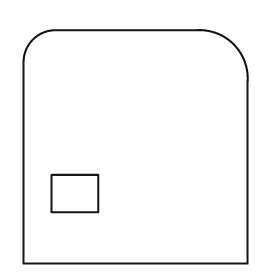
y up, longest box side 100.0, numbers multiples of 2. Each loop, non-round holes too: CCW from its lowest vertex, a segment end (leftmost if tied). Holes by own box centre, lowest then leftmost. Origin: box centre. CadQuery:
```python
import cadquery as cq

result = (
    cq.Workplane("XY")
    .moveTo(-48.0, -50.0)
    .lineTo(48.0, -50.0)
    .lineTo(48.0, 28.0)
    .threePointArc((42.0, 44.0), (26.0, 50.0))
    .lineTo(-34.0, 50.0)
    .threePointArc((-44.0, 46.0), (-48.0, 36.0))
    .close()
    .moveTo(-36.0, -28.0)
    .lineTo(-16.0, -28.0)
    .lineTo(-16.0, -12.0)
    .lineTo(-36.0, -12.0)
    .close()
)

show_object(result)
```